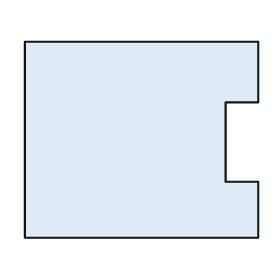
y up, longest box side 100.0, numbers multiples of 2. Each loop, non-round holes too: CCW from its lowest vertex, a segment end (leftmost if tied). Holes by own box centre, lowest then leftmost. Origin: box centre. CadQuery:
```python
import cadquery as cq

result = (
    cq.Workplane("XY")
    .moveTo(-50.0, -42.0)
    .lineTo(50.0, -42.0)
    .lineTo(50.0, -18.0)
    .lineTo(36.0, -18.0)
    .lineTo(36.0, 16.0)
    .lineTo(50.0, 16.0)
    .lineTo(50.0, 42.0)
    .lineTo(-50.0, 42.0)
    .close()
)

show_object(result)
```